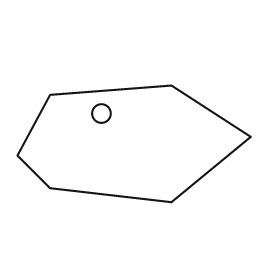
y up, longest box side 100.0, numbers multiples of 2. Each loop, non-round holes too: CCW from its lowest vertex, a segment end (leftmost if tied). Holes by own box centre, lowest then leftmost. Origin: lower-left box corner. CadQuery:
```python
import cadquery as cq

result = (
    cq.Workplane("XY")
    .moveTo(66.0, 0.0)
    .lineTo(100.0, 28.0)
    .lineTo(66.0, 50.0)
    .lineTo(14.0, 46.0)
    .lineTo(0.0, 20.0)
    .lineTo(14.0, 6.0)
    .close()
    .moveTo(36.0, 38.0)
    .circle(4.0)
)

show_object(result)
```